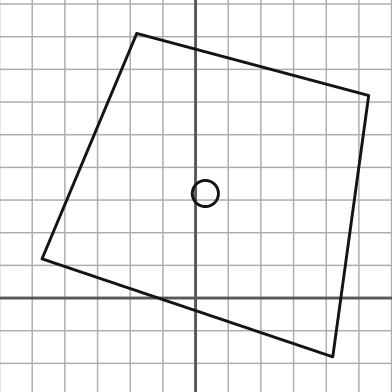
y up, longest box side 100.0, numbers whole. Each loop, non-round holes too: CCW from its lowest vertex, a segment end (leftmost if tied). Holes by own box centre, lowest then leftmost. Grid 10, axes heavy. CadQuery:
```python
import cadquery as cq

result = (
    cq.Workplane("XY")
    .moveTo(42.0, -18.0)
    .lineTo(53.0, 62.0)
    .lineTo(-18.0, 81.0)
    .lineTo(-47.0, 12.0)
    .close()
    .moveTo(3.0, 32.0)
    .circle(4.0)
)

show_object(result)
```